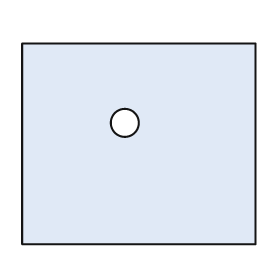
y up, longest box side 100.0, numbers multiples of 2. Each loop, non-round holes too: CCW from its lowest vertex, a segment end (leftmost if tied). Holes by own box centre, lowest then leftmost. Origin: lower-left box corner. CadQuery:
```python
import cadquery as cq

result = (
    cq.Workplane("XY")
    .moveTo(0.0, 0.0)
    .lineTo(100.0, 0.0)
    .lineTo(100.0, 86.0)
    .lineTo(0.0, 86.0)
    .close()
    .moveTo(44.0, 52.0)
    .circle(6.0)
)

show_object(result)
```